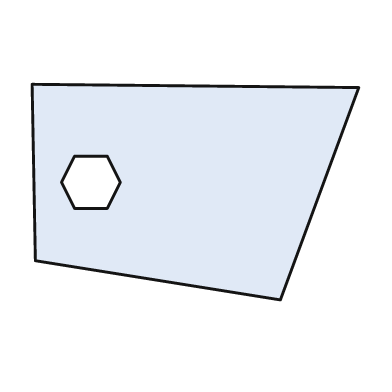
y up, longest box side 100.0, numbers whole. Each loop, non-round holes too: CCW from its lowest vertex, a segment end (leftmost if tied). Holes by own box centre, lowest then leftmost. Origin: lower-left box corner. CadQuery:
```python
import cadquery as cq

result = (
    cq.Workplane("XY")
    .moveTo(76.0, 0.0)
    .lineTo(100.0, 65.0)
    .lineTo(0.0, 66.0)
    .lineTo(1.0, 12.0)
    .close()
    .moveTo(13.0, 28.0)
    .lineTo(23.0, 28.0)
    .lineTo(27.0, 36.0)
    .lineTo(23.0, 44.0)
    .lineTo(13.0, 44.0)
    .lineTo(9.0, 36.0)
    .close()
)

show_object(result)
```